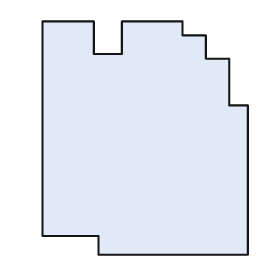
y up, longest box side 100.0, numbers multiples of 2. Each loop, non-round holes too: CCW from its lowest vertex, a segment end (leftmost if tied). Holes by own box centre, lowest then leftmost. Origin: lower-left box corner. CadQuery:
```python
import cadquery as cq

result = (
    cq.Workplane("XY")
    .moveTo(24.0, 0.0)
    .lineTo(88.0, 0.0)
    .lineTo(88.0, 64.0)
    .lineTo(80.0, 64.0)
    .lineTo(80.0, 84.0)
    .lineTo(70.0, 84.0)
    .lineTo(70.0, 94.0)
    .lineTo(60.0, 94.0)
    .lineTo(60.0, 100.0)
    .lineTo(34.0, 100.0)
    .lineTo(34.0, 86.0)
    .lineTo(22.0, 86.0)
    .lineTo(22.0, 100.0)
    .lineTo(0.0, 100.0)
    .lineTo(0.0, 8.0)
    .lineTo(24.0, 8.0)
    .close()
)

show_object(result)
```